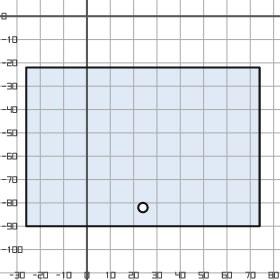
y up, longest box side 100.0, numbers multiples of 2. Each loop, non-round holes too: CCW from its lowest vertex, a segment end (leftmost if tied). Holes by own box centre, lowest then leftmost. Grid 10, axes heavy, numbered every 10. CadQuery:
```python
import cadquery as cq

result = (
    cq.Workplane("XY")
    .moveTo(-26.0, -90.0)
    .lineTo(74.0, -90.0)
    .lineTo(74.0, -22.0)
    .lineTo(-26.0, -22.0)
    .close()
    .moveTo(24.0, -82.0)
    .circle(2.0)
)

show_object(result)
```